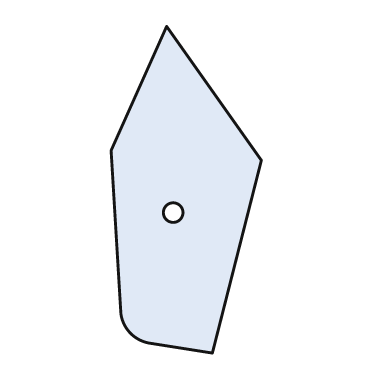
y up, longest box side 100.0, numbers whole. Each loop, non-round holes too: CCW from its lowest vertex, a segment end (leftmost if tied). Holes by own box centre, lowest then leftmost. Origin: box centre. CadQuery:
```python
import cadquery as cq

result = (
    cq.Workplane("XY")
    .moveTo(8.0, -50.0)
    .lineTo(23.0, 9.0)
    .lineTo(-6.0, 50.0)
    .lineTo(-23.0, 12.0)
    .lineTo(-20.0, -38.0)
    .threePointArc((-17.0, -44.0), (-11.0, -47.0))
    .close()
    .moveTo(-4.0, -7.0)
    .circle(3.0)
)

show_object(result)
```